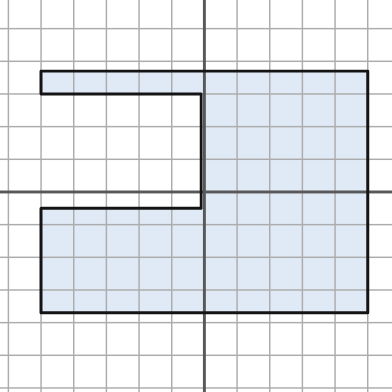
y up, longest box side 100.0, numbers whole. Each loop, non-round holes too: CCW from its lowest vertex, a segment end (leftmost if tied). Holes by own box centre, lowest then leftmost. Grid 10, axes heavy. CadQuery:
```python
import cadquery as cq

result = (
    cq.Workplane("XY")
    .moveTo(-50.0, -37.0)
    .lineTo(50.0, -37.0)
    .lineTo(50.0, 37.0)
    .lineTo(-50.0, 37.0)
    .lineTo(-50.0, 30.0)
    .lineTo(-1.0, 30.0)
    .lineTo(-1.0, -5.0)
    .lineTo(-50.0, -5.0)
    .close()
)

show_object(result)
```